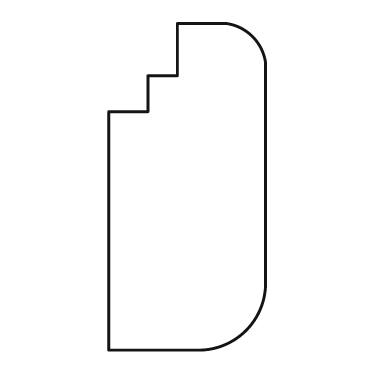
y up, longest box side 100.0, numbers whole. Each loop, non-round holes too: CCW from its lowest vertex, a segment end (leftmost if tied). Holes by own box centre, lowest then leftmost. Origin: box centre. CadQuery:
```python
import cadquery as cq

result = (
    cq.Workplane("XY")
    .moveTo(-24.0, -50.0)
    .lineTo(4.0, -50.0)
    .threePointArc((18.0, -44.0), (24.0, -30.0))
    .lineTo(24.0, 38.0)
    .threePointArc((20.0, 46.0), (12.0, 50.0))
    .lineTo(-3.0, 50.0)
    .lineTo(-3.0, 34.0)
    .lineTo(-12.0, 34.0)
    .lineTo(-12.0, 23.0)
    .lineTo(-24.0, 23.0)
    .close()
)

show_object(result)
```